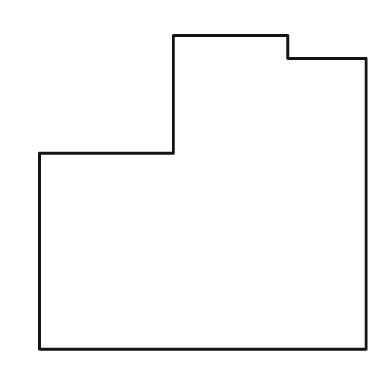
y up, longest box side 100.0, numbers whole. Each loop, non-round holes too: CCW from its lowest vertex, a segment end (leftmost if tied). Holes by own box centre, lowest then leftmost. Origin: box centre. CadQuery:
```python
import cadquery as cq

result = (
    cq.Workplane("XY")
    .moveTo(-50.0, -48.0)
    .lineTo(50.0, -48.0)
    .lineTo(50.0, 41.0)
    .lineTo(26.0, 41.0)
    .lineTo(26.0, 48.0)
    .lineTo(-9.0, 48.0)
    .lineTo(-9.0, 12.0)
    .lineTo(-50.0, 12.0)
    .close()
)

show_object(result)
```